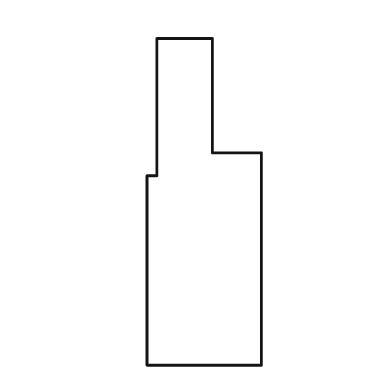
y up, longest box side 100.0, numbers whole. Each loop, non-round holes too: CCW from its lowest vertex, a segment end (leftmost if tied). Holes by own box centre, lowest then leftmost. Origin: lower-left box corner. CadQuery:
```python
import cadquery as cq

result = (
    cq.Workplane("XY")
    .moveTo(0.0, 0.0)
    .lineTo(35.0, 0.0)
    .lineTo(35.0, 65.0)
    .lineTo(20.0, 65.0)
    .lineTo(20.0, 100.0)
    .lineTo(3.0, 100.0)
    .lineTo(3.0, 58.0)
    .lineTo(0.0, 58.0)
    .close()
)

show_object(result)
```